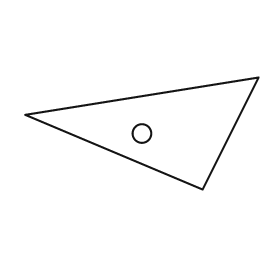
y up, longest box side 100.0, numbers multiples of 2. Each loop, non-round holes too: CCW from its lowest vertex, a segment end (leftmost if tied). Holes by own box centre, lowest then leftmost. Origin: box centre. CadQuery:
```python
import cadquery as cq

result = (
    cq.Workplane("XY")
    .moveTo(26.0, -24.0)
    .lineTo(50.0, 24.0)
    .lineTo(-50.0, 8.0)
    .close()
    .moveTo(0.0, 0.0)
    .circle(4.0)
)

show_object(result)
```